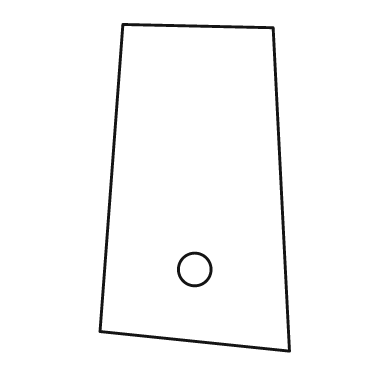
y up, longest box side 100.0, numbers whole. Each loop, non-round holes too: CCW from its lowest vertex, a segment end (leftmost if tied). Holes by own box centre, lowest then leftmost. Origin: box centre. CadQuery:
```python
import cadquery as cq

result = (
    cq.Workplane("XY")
    .moveTo(29.0, -50.0)
    .lineTo(24.0, 49.0)
    .lineTo(-22.0, 50.0)
    .lineTo(-29.0, -44.0)
    .close()
    .moveTo(0.0, -25.0)
    .circle(5.0)
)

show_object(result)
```